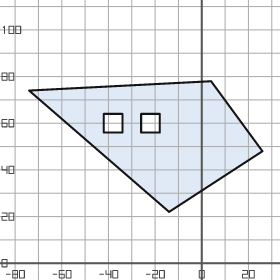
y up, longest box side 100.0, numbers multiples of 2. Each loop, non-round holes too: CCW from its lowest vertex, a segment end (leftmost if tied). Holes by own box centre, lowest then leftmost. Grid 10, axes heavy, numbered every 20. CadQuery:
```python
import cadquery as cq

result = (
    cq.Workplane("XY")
    .moveTo(-14.0, 22.0)
    .lineTo(26.0, 48.0)
    .lineTo(4.0, 78.0)
    .lineTo(-74.0, 74.0)
    .close()
    .moveTo(-42.0, 56.0)
    .lineTo(-34.0, 56.0)
    .lineTo(-34.0, 64.0)
    .lineTo(-42.0, 64.0)
    .close()
    .moveTo(-26.0, 56.0)
    .lineTo(-18.0, 56.0)
    .lineTo(-18.0, 64.0)
    .lineTo(-26.0, 64.0)
    .close()
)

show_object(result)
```